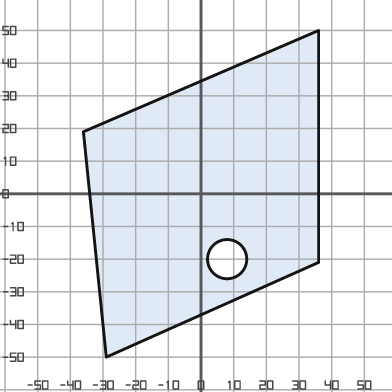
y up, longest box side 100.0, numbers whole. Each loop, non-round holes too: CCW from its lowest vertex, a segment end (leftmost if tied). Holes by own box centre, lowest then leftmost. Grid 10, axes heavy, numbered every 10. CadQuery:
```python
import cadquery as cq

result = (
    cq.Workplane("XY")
    .moveTo(-29.0, -50.0)
    .lineTo(36.0, -21.0)
    .lineTo(36.0, 50.0)
    .lineTo(-36.0, 19.0)
    .close()
    .moveTo(8.0, -20.0)
    .circle(6.0)
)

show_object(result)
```